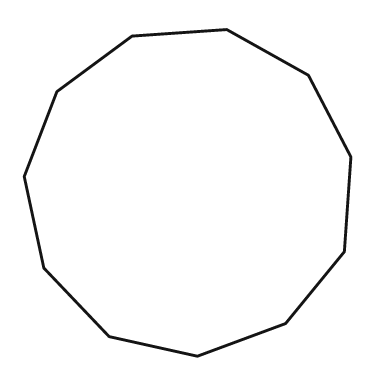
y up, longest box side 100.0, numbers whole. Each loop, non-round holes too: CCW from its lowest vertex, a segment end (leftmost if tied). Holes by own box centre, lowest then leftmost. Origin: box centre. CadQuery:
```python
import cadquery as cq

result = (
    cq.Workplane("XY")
    .moveTo(3.0, -50.0)
    .lineTo(30.0, -40.0)
    .lineTo(48.0, -18.0)
    .lineTo(50.0, 11.0)
    .lineTo(37.0, 36.0)
    .lineTo(12.0, 50.0)
    .lineTo(-17.0, 48.0)
    .lineTo(-40.0, 31.0)
    .lineTo(-50.0, 5.0)
    .lineTo(-44.0, -23.0)
    .lineTo(-24.0, -44.0)
    .close()
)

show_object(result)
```